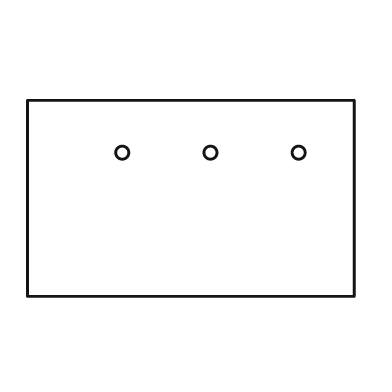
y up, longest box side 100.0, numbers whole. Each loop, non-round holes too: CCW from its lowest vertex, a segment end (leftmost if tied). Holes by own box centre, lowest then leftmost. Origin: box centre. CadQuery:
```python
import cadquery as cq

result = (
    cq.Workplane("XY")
    .moveTo(-50.0, -30.0)
    .lineTo(50.0, -30.0)
    .lineTo(50.0, 30.0)
    .lineTo(-50.0, 30.0)
    .close()
    .moveTo(-21.0, 14.0)
    .circle(2.0)
    .moveTo(6.0, 14.0)
    .circle(2.0)
    .moveTo(33.0, 14.0)
    .circle(2.0)
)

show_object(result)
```